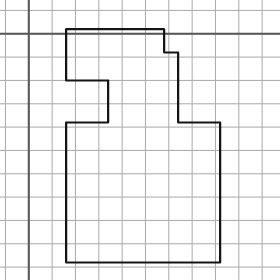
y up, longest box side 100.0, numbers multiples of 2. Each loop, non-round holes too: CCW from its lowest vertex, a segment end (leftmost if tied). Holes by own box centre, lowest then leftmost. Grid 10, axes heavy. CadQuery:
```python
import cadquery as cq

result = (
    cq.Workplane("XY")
    .moveTo(16.0, -98.0)
    .lineTo(82.0, -98.0)
    .lineTo(82.0, -38.0)
    .lineTo(64.0, -38.0)
    .lineTo(64.0, -8.0)
    .lineTo(58.0, -8.0)
    .lineTo(58.0, 2.0)
    .lineTo(16.0, 2.0)
    .lineTo(16.0, -20.0)
    .lineTo(34.0, -20.0)
    .lineTo(34.0, -38.0)
    .lineTo(16.0, -38.0)
    .close()
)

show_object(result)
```